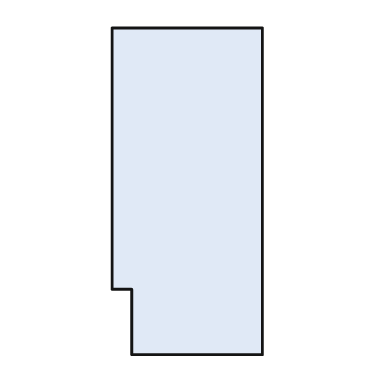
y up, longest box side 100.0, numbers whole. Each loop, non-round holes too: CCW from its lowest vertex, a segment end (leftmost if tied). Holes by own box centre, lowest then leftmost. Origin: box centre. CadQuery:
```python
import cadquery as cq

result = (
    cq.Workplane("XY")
    .moveTo(-17.0, -50.0)
    .lineTo(23.0, -50.0)
    .lineTo(23.0, 50.0)
    .lineTo(-23.0, 50.0)
    .lineTo(-23.0, -30.0)
    .lineTo(-17.0, -30.0)
    .close()
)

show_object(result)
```